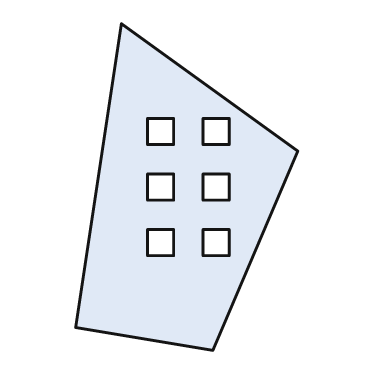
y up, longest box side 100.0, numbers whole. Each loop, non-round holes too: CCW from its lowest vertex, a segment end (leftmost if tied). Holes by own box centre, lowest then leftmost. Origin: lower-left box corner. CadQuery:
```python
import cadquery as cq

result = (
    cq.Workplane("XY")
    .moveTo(42.0, 0.0)
    .lineTo(68.0, 61.0)
    .lineTo(14.0, 100.0)
    .lineTo(0.0, 7.0)
    .close()
    .moveTo(22.0, 29.0)
    .lineTo(30.0, 29.0)
    .lineTo(30.0, 37.0)
    .lineTo(22.0, 37.0)
    .close()
    .moveTo(39.0, 29.0)
    .lineTo(47.0, 29.0)
    .lineTo(47.0, 37.0)
    .lineTo(39.0, 37.0)
    .close()
    .moveTo(22.0, 46.0)
    .lineTo(30.0, 46.0)
    .lineTo(30.0, 54.0)
    .lineTo(22.0, 54.0)
    .close()
    .moveTo(39.0, 46.0)
    .lineTo(47.0, 46.0)
    .lineTo(47.0, 54.0)
    .lineTo(39.0, 54.0)
    .close()
    .moveTo(22.0, 63.0)
    .lineTo(30.0, 63.0)
    .lineTo(30.0, 71.0)
    .lineTo(22.0, 71.0)
    .close()
    .moveTo(39.0, 63.0)
    .lineTo(47.0, 63.0)
    .lineTo(47.0, 71.0)
    .lineTo(39.0, 71.0)
    .close()
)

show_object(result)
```